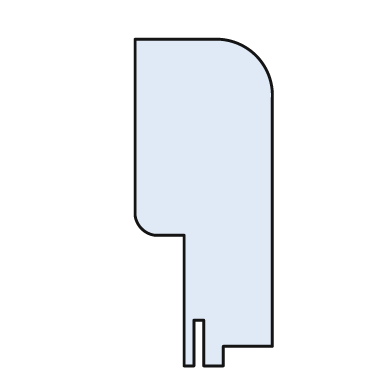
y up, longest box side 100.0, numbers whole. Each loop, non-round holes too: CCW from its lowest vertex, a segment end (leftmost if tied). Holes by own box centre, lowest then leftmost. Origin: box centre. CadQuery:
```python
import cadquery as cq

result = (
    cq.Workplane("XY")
    .moveTo(-6.0, -50.0)
    .lineTo(-3.0, -50.0)
    .lineTo(-3.0, -36.0)
    .lineTo(0.0, -36.0)
    .lineTo(0.0, -50.0)
    .lineTo(6.0, -50.0)
    .lineTo(6.0, -44.0)
    .lineTo(21.0, -44.0)
    .lineTo(21.0, 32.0)
    .threePointArc((16.0, 45.0), (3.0, 50.0))
    .lineTo(-21.0, 50.0)
    .lineTo(-21.0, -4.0)
    .threePointArc((-19.0, -8.0), (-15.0, -10.0))
    .lineTo(-6.0, -10.0)
    .close()
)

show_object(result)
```